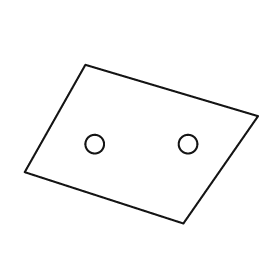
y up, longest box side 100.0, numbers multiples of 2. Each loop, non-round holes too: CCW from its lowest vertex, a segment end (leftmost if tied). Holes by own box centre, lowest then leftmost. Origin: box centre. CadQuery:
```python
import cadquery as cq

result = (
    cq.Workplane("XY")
    .moveTo(18.0, -34.0)
    .lineTo(50.0, 12.0)
    .lineTo(-24.0, 34.0)
    .lineTo(-50.0, -12.0)
    .close()
    .moveTo(-20.0, 0.0)
    .circle(4.0)
    .moveTo(20.0, 0.0)
    .circle(4.0)
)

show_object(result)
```